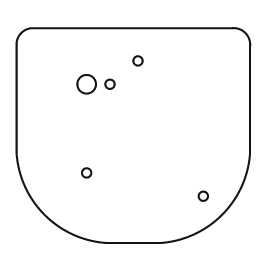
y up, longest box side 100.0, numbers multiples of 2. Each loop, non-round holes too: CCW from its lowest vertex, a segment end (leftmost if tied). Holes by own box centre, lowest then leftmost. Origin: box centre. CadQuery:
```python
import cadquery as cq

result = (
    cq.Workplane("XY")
    .moveTo(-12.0, -46.0)
    .lineTo(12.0, -46.0)
    .threePointArc((38.0, -34.0), (50.0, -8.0))
    .lineTo(50.0, 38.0)
    .threePointArc((48.0, 44.0), (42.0, 46.0))
    .lineTo(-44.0, 46.0)
    .threePointArc((-48.0, 44.0), (-50.0, 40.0))
    .lineTo(-50.0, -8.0)
    .threePointArc((-38.0, -34.0), (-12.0, -46.0))
    .close()
    .moveTo(30.0, -26.0)
    .circle(2.0)
    .moveTo(-20.0, -16.0)
    .circle(2.0)
    .moveTo(-20.0, 22.0)
    .circle(4.0)
    .moveTo(-10.0, 22.0)
    .circle(2.0)
    .moveTo(2.0, 32.0)
    .circle(2.0)
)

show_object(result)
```